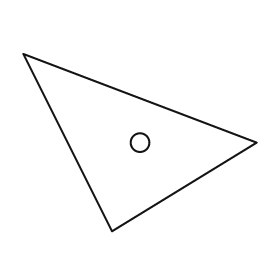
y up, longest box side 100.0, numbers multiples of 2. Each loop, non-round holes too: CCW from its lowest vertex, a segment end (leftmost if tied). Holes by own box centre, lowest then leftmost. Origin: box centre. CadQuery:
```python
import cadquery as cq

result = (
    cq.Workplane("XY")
    .moveTo(-12.0, -38.0)
    .lineTo(50.0, 0.0)
    .lineTo(-50.0, 38.0)
    .close()
    .moveTo(0.0, 0.0)
    .circle(4.0)
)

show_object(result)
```